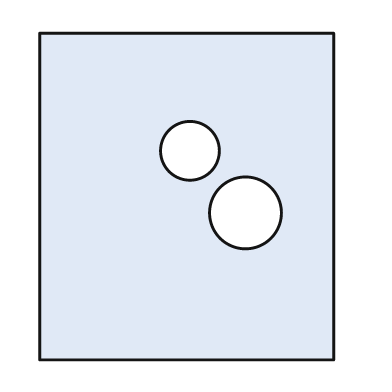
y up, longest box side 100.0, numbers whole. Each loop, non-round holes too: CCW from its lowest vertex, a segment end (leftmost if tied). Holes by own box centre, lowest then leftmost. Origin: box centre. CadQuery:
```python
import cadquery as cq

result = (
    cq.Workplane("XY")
    .moveTo(-45.0, -50.0)
    .lineTo(45.0, -50.0)
    .lineTo(45.0, 50.0)
    .lineTo(-45.0, 50.0)
    .close()
    .moveTo(18.0, -5.0)
    .circle(11.0)
    .moveTo(1.0, 14.0)
    .circle(9.0)
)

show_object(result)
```